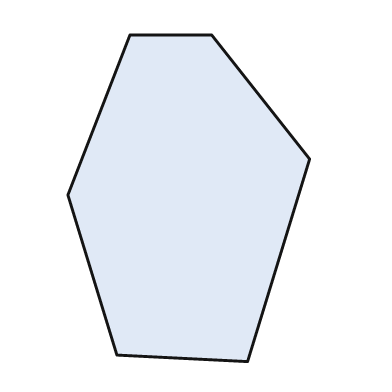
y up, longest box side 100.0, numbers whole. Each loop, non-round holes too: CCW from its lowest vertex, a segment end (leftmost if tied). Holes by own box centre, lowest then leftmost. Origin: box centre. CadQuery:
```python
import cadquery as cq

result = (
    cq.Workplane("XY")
    .moveTo(18.0, -50.0)
    .lineTo(37.0, 12.0)
    .lineTo(7.0, 50.0)
    .lineTo(-18.0, 50.0)
    .lineTo(-37.0, 1.0)
    .lineTo(-22.0, -48.0)
    .close()
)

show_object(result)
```